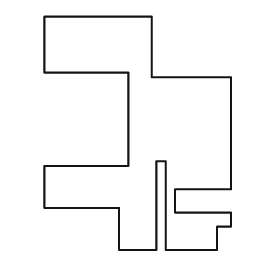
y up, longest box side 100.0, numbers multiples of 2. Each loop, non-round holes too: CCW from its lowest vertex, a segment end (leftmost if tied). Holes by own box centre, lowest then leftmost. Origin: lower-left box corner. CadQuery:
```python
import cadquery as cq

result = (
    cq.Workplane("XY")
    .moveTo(32.0, 0.0)
    .lineTo(48.0, 0.0)
    .lineTo(48.0, 38.0)
    .lineTo(52.0, 38.0)
    .lineTo(52.0, 0.0)
    .lineTo(74.0, 0.0)
    .lineTo(74.0, 10.0)
    .lineTo(80.0, 10.0)
    .lineTo(80.0, 16.0)
    .lineTo(56.0, 16.0)
    .lineTo(56.0, 26.0)
    .lineTo(80.0, 26.0)
    .lineTo(80.0, 74.0)
    .lineTo(46.0, 74.0)
    .lineTo(46.0, 100.0)
    .lineTo(0.0, 100.0)
    .lineTo(0.0, 76.0)
    .lineTo(36.0, 76.0)
    .lineTo(36.0, 36.0)
    .lineTo(0.0, 36.0)
    .lineTo(0.0, 18.0)
    .lineTo(32.0, 18.0)
    .close()
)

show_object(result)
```